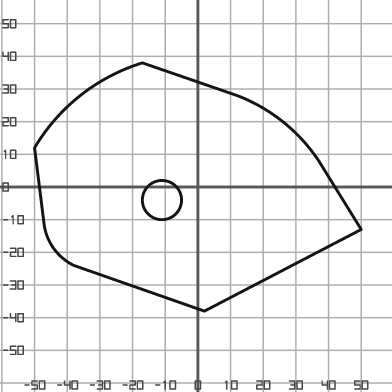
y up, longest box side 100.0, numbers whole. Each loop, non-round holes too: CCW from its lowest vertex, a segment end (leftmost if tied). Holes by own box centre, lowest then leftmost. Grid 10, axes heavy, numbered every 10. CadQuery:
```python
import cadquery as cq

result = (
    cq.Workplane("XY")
    .moveTo(2.0, -38.0)
    .lineTo(50.0, -13.0)
    .lineTo(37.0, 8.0)
    .threePointArc((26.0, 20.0), (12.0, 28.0))
    .lineTo(-17.0, 38.0)
    .threePointArc((-36.0, 28.0), (-50.0, 12.0))
    .lineTo(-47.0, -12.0)
    .threePointArc((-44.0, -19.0), (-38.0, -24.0))
    .close()
    .moveTo(-11.0, -4.0)
    .circle(6.0)
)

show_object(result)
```